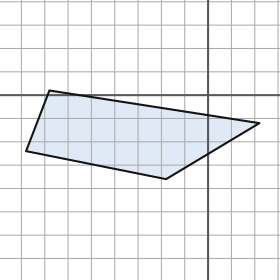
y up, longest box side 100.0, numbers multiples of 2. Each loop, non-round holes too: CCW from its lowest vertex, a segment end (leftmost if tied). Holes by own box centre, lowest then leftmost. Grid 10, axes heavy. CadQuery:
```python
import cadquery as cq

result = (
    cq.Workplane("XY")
    .moveTo(-18.0, -36.0)
    .lineTo(22.0, -12.0)
    .lineTo(-68.0, 2.0)
    .lineTo(-78.0, -24.0)
    .close()
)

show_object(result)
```